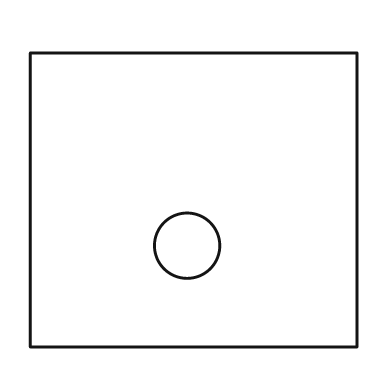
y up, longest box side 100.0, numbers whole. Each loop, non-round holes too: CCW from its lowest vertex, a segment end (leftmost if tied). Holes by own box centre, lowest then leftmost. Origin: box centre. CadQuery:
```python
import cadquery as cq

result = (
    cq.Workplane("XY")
    .moveTo(-50.0, -45.0)
    .lineTo(50.0, -45.0)
    .lineTo(50.0, 45.0)
    .lineTo(-50.0, 45.0)
    .close()
    .moveTo(-2.0, -14.0)
    .circle(10.0)
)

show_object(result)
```